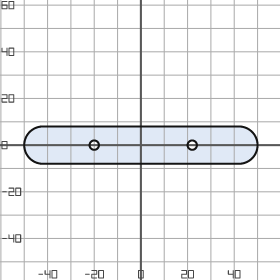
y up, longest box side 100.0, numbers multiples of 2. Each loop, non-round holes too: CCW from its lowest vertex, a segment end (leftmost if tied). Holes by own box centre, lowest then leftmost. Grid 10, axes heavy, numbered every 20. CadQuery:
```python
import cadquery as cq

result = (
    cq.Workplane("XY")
    .moveTo(-42.0, -8.0)
    .lineTo(42.0, -8.0)
    .threePointArc((50.0, 0.0), (42.0, 8.0))
    .lineTo(-42.0, 8.0)
    .threePointArc((-50.0, 0.0), (-42.0, -8.0))
    .close()
    .moveTo(-20.0, 0.0)
    .circle(2.0)
    .moveTo(22.0, 0.0)
    .circle(2.0)
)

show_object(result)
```